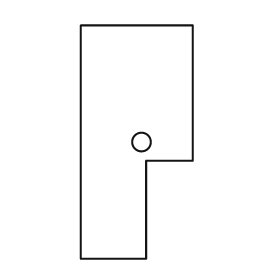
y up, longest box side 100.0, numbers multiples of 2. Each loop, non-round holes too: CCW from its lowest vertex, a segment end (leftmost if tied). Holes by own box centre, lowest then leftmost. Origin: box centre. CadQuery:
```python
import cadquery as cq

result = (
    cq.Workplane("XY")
    .moveTo(-24.0, -50.0)
    .lineTo(4.0, -50.0)
    .lineTo(4.0, -8.0)
    .lineTo(24.0, -8.0)
    .lineTo(24.0, 50.0)
    .lineTo(-24.0, 50.0)
    .close()
    .moveTo(2.0, 0.0)
    .circle(4.0)
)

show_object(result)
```